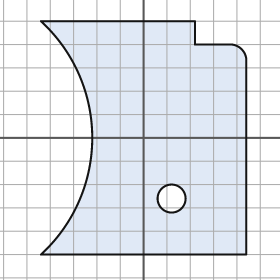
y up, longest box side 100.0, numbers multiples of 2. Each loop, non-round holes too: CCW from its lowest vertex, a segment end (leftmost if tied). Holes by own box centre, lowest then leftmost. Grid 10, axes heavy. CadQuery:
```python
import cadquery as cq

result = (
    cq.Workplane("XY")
    .moveTo(-44.0, -50.0)
    .lineTo(44.0, -50.0)
    .lineTo(44.0, 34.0)
    .threePointArc((42.0, 38.0), (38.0, 40.0))
    .lineTo(22.0, 40.0)
    .lineTo(22.0, 50.0)
    .lineTo(-44.0, 50.0)
    .threePointArc((-22.0, 0.0), (-44.0, -50.0))
    .close()
    .moveTo(12.0, -26.0)
    .circle(6.0)
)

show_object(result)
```